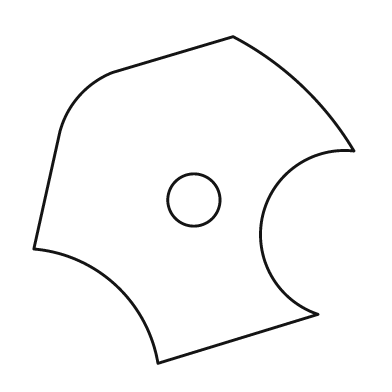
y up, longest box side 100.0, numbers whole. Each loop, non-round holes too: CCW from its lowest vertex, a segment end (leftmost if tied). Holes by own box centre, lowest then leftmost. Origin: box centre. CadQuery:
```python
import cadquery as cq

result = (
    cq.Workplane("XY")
    .moveTo(-11.0, -50.0)
    .lineTo(38.0, -35.0)
    .threePointArc((21.0, -5.0), (49.0, 15.0))
    .threePointArc((33.0, 35.0), (12.0, 50.0))
    .lineTo(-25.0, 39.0)
    .threePointArc((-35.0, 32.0), (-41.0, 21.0))
    .lineTo(-49.0, -15.0)
    .threePointArc((-24.0, -26.0), (-11.0, -50.0))
    .close()
    .moveTo(0.0, 0.0)
    .circle(8.0)
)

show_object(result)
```